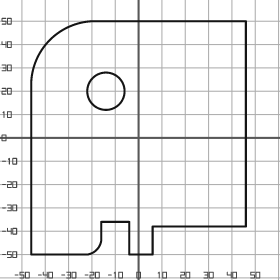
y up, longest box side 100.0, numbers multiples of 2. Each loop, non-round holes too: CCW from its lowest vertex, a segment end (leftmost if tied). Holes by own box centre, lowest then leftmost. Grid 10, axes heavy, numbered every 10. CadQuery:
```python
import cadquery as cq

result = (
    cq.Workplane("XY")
    .moveTo(-46.0, -50.0)
    .lineTo(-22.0, -50.0)
    .threePointArc((-18.0, -48.0), (-16.0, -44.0))
    .lineTo(-16.0, -36.0)
    .lineTo(-4.0, -36.0)
    .lineTo(-4.0, -50.0)
    .lineTo(6.0, -50.0)
    .lineTo(6.0, -38.0)
    .lineTo(46.0, -38.0)
    .lineTo(46.0, 50.0)
    .lineTo(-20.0, 50.0)
    .threePointArc((-38.0, 42.0), (-46.0, 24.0))
    .close()
    .moveTo(-14.0, 20.0)
    .circle(8.0)
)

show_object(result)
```